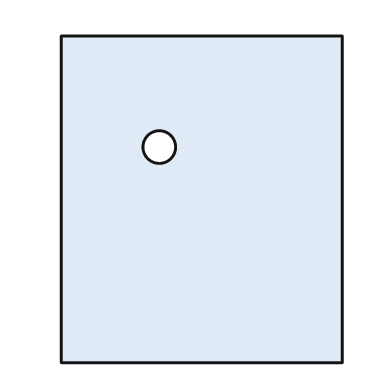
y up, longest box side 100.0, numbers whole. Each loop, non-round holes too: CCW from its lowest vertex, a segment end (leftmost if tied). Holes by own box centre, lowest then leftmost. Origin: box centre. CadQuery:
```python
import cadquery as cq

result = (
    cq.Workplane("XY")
    .moveTo(-43.0, -50.0)
    .lineTo(43.0, -50.0)
    .lineTo(43.0, 50.0)
    .lineTo(-43.0, 50.0)
    .close()
    .moveTo(-13.0, 16.0)
    .circle(5.0)
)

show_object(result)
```